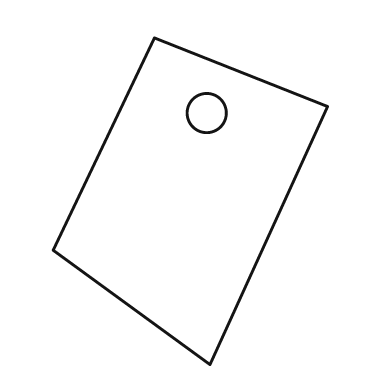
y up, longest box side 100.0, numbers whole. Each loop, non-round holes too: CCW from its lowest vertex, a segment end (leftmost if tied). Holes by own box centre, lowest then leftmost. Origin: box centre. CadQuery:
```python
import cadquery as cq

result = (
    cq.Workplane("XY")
    .moveTo(6.0, -50.0)
    .lineTo(42.0, 29.0)
    .lineTo(-11.0, 50.0)
    .lineTo(-42.0, -15.0)
    .close()
    .moveTo(5.0, 27.0)
    .circle(6.0)
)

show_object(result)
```